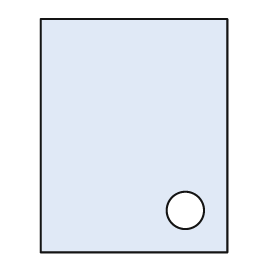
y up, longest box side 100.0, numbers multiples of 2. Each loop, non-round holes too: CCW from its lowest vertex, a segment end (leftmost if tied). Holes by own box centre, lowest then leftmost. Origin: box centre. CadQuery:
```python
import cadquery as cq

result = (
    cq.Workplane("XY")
    .moveTo(-40.0, -50.0)
    .lineTo(40.0, -50.0)
    .lineTo(40.0, 50.0)
    .lineTo(-40.0, 50.0)
    .close()
    .moveTo(22.0, -32.0)
    .circle(8.0)
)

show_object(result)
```